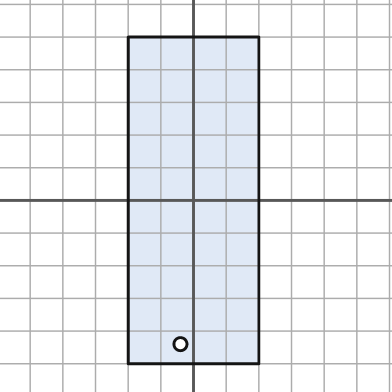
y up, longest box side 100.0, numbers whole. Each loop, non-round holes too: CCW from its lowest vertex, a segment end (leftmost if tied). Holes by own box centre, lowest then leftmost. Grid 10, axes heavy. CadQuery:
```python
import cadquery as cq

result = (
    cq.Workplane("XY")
    .moveTo(-20.0, -50.0)
    .lineTo(20.0, -50.0)
    .lineTo(20.0, 50.0)
    .lineTo(-20.0, 50.0)
    .close()
    .moveTo(-4.0, -44.0)
    .circle(2.0)
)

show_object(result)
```